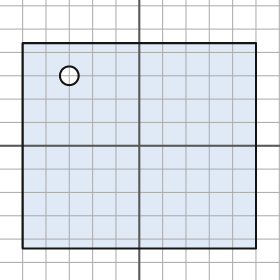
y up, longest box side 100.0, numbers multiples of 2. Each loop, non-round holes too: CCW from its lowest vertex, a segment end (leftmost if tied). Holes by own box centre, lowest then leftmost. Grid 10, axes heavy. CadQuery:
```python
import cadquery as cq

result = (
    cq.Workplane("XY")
    .moveTo(-50.0, -44.0)
    .lineTo(50.0, -44.0)
    .lineTo(50.0, 44.0)
    .lineTo(-50.0, 44.0)
    .close()
    .moveTo(-30.0, 30.0)
    .circle(4.0)
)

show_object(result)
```